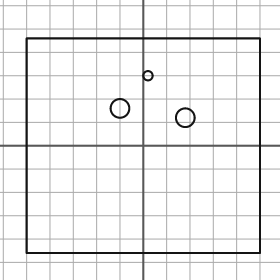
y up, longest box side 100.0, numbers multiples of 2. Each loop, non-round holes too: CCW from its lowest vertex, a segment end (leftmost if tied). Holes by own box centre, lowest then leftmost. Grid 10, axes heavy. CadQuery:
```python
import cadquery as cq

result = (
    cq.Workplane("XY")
    .moveTo(-50.0, -46.0)
    .lineTo(50.0, -46.0)
    .lineTo(50.0, 46.0)
    .lineTo(-50.0, 46.0)
    .close()
    .moveTo(18.0, 12.0)
    .circle(4.0)
    .moveTo(-10.0, 16.0)
    .circle(4.0)
    .moveTo(2.0, 30.0)
    .circle(2.0)
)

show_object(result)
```